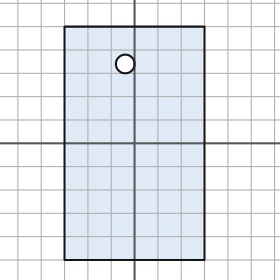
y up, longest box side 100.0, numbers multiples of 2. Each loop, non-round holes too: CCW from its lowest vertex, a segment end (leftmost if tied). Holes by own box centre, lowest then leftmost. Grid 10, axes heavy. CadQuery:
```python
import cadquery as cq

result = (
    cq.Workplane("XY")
    .moveTo(-30.0, -50.0)
    .lineTo(30.0, -50.0)
    .lineTo(30.0, 50.0)
    .lineTo(-30.0, 50.0)
    .close()
    .moveTo(-4.0, 34.0)
    .circle(4.0)
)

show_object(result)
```